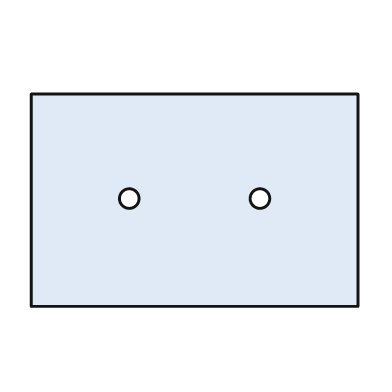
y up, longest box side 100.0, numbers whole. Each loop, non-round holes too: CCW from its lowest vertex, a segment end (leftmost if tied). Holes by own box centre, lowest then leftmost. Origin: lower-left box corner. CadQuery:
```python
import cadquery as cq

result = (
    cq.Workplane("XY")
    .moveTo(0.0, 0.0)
    .lineTo(100.0, 0.0)
    .lineTo(100.0, 65.0)
    .lineTo(0.0, 65.0)
    .close()
    .moveTo(30.0, 33.0)
    .circle(3.0)
    .moveTo(70.0, 33.0)
    .circle(3.0)
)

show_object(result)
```